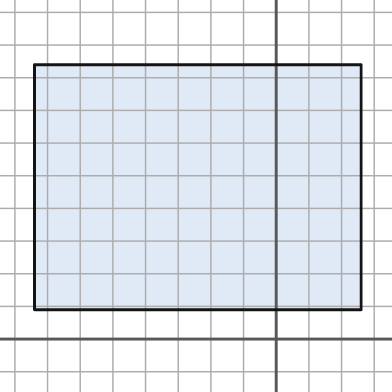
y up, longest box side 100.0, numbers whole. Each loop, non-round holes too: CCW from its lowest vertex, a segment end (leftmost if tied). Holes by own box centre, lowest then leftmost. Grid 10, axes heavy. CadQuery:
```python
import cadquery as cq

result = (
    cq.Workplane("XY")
    .moveTo(-74.0, 9.0)
    .lineTo(26.0, 9.0)
    .lineTo(26.0, 84.0)
    .lineTo(-74.0, 84.0)
    .close()
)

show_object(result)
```